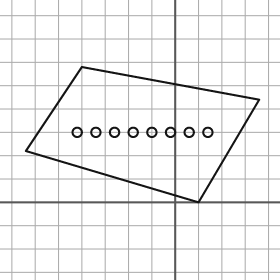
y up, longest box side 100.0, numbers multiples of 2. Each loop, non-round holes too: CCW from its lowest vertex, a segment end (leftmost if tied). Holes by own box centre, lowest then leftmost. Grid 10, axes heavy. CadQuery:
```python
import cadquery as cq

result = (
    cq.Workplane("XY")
    .moveTo(10.0, 0.0)
    .lineTo(36.0, 44.0)
    .lineTo(-40.0, 58.0)
    .lineTo(-64.0, 22.0)
    .close()
    .moveTo(-42.0, 30.0)
    .circle(2.0)
    .moveTo(-34.0, 30.0)
    .circle(2.0)
    .moveTo(-26.0, 30.0)
    .circle(2.0)
    .moveTo(-18.0, 30.0)
    .circle(2.0)
    .moveTo(-10.0, 30.0)
    .circle(2.0)
    .moveTo(-2.0, 30.0)
    .circle(2.0)
    .moveTo(6.0, 30.0)
    .circle(2.0)
    .moveTo(14.0, 30.0)
    .circle(2.0)
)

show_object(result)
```